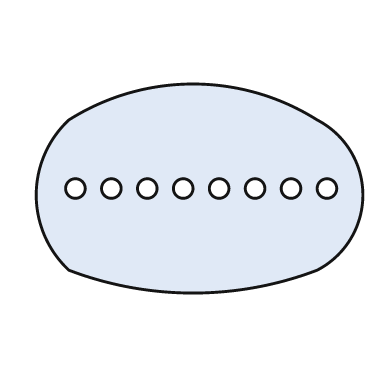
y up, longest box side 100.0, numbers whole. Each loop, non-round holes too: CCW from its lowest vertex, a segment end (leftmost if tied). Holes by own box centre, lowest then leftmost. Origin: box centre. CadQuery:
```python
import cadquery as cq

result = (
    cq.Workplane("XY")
    .moveTo(-40.0, -25.0)
    .threePointArc((-2.0, -32.0), (36.0, -25.0))
    .threePointArc((50.0, -2.0), (36.0, 21.0))
    .threePointArc((-2.0, 32.0), (-40.0, 21.0))
    .threePointArc((-50.0, -2.0), (-40.0, -25.0))
    .close()
    .moveTo(-38.0, 0.0)
    .circle(3.0)
    .moveTo(-27.0, 0.0)
    .circle(3.0)
    .moveTo(-16.0, 0.0)
    .circle(3.0)
    .moveTo(-5.0, 0.0)
    .circle(3.0)
    .moveTo(6.0, 0.0)
    .circle(3.0)
    .moveTo(17.0, 0.0)
    .circle(3.0)
    .moveTo(28.0, 0.0)
    .circle(3.0)
    .moveTo(39.0, 0.0)
    .circle(3.0)
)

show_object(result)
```